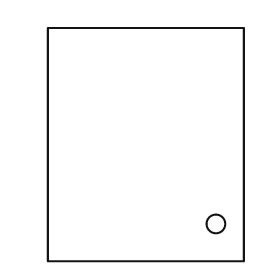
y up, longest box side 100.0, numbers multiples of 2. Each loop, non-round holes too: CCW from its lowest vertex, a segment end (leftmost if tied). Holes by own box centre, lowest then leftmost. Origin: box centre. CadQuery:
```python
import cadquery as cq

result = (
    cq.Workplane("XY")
    .moveTo(-42.0, -50.0)
    .lineTo(42.0, -50.0)
    .lineTo(42.0, 50.0)
    .lineTo(-42.0, 50.0)
    .close()
    .moveTo(30.0, -34.0)
    .circle(4.0)
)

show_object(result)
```